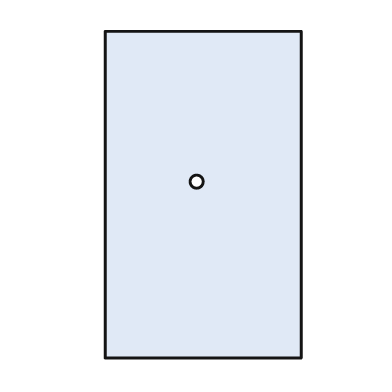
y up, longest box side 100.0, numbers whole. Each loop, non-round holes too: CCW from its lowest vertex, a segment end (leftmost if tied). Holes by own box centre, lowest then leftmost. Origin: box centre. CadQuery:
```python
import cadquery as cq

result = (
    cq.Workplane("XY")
    .moveTo(-30.0, -50.0)
    .lineTo(30.0, -50.0)
    .lineTo(30.0, 50.0)
    .lineTo(-30.0, 50.0)
    .close()
    .moveTo(-2.0, 4.0)
    .circle(2.0)
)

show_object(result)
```